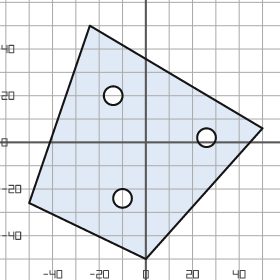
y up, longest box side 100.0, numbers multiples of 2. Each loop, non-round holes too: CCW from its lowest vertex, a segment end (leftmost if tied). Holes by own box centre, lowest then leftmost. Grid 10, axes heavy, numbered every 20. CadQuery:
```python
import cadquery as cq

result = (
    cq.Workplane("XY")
    .moveTo(0.0, -50.0)
    .lineTo(50.0, 6.0)
    .lineTo(-24.0, 50.0)
    .lineTo(-50.0, -26.0)
    .close()
    .moveTo(-10.0, -24.0)
    .circle(4.0)
    .moveTo(26.0, 2.0)
    .circle(4.0)
    .moveTo(-14.0, 20.0)
    .circle(4.0)
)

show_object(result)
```